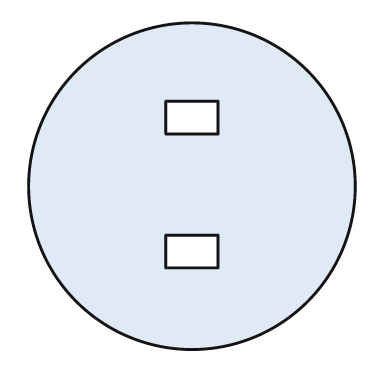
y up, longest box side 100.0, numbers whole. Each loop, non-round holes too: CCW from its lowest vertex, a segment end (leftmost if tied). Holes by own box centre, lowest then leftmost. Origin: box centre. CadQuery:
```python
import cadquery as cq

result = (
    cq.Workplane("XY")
    .moveTo(0.0, 0.0)
    .circle(50.0)
    .moveTo(-8.0, -25.0)
    .lineTo(8.0, -25.0)
    .lineTo(8.0, -15.0)
    .lineTo(-8.0, -15.0)
    .close()
    .moveTo(-8.0, 16.0)
    .lineTo(8.0, 16.0)
    .lineTo(8.0, 26.0)
    .lineTo(-8.0, 26.0)
    .close()
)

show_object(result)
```